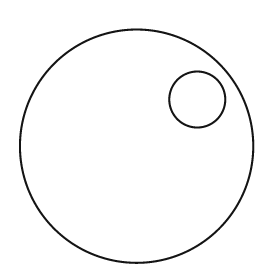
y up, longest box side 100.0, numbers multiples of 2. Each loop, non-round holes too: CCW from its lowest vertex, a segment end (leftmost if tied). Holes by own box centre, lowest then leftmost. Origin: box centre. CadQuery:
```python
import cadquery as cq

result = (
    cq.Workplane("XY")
    .moveTo(0.0, 0.0)
    .circle(50.0)
    .moveTo(26.0, 20.0)
    .circle(12.0)
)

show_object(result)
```